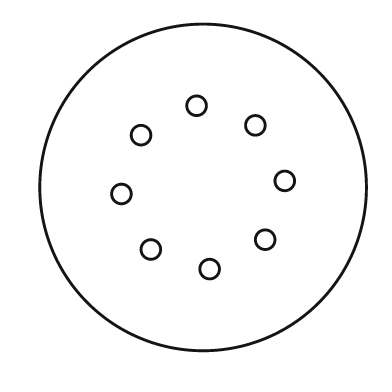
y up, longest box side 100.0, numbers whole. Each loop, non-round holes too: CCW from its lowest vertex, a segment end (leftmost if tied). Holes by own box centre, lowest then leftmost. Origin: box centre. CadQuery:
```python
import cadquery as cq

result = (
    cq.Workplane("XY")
    .moveTo(0.0, 0.0)
    .circle(50.0)
    .moveTo(2.0, -25.0)
    .circle(3.0)
    .moveTo(-16.0, -19.0)
    .circle(3.0)
    .moveTo(19.0, -16.0)
    .circle(3.0)
    .moveTo(-25.0, -2.0)
    .circle(3.0)
    .moveTo(25.0, 2.0)
    .circle(3.0)
    .moveTo(-19.0, 16.0)
    .circle(3.0)
    .moveTo(16.0, 19.0)
    .circle(3.0)
    .moveTo(-2.0, 25.0)
    .circle(3.0)
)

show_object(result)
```